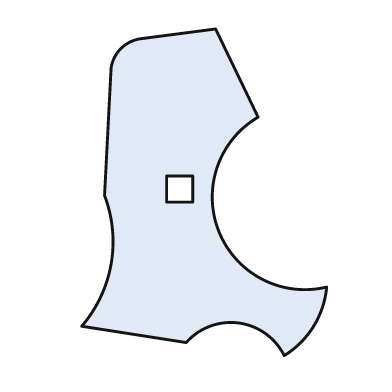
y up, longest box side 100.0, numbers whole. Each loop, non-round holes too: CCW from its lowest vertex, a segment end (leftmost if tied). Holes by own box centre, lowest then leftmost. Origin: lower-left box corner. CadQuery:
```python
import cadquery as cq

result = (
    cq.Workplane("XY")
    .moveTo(62.0, 0.0)
    .threePointArc((71.0, 9.0), (75.0, 21.0))
    .threePointArc((42.0, 38.0), (54.0, 73.0))
    .lineTo(41.0, 100.0)
    .lineTo(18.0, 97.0)
    .threePointArc((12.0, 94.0), (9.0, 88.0))
    .lineTo(7.0, 49.0)
    .threePointArc((9.0, 28.0), (0.0, 9.0))
    .lineTo(32.0, 4.0)
    .threePointArc((48.0, 10.0), (62.0, 0.0))
    .close()
    .moveTo(26.0, 47.0)
    .lineTo(34.0, 47.0)
    .lineTo(34.0, 55.0)
    .lineTo(26.0, 55.0)
    .close()
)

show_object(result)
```